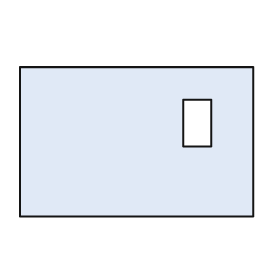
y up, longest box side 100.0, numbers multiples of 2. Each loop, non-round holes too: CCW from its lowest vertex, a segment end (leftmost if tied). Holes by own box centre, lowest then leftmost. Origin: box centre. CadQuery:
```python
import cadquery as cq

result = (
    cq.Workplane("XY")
    .moveTo(-50.0, -32.0)
    .lineTo(50.0, -32.0)
    .lineTo(50.0, 32.0)
    .lineTo(-50.0, 32.0)
    .close()
    .moveTo(20.0, -2.0)
    .lineTo(32.0, -2.0)
    .lineTo(32.0, 18.0)
    .lineTo(20.0, 18.0)
    .close()
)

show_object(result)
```